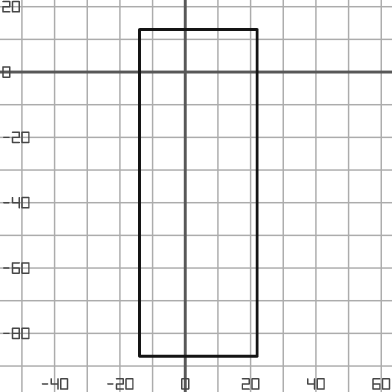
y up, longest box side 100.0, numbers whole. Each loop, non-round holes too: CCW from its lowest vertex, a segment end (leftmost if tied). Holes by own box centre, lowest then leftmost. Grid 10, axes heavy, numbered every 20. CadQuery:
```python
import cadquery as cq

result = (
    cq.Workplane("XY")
    .moveTo(-14.0, -87.0)
    .lineTo(22.0, -87.0)
    .lineTo(22.0, 13.0)
    .lineTo(-14.0, 13.0)
    .close()
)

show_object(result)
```